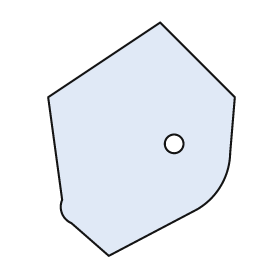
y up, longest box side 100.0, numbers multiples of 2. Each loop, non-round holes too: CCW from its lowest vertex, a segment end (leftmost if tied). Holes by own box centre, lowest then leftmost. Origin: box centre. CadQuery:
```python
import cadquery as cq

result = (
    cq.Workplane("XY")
    .moveTo(-14.0, -50.0)
    .lineTo(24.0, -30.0)
    .threePointArc((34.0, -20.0), (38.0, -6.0))
    .lineTo(40.0, 18.0)
    .lineTo(8.0, 50.0)
    .lineTo(-40.0, 18.0)
    .lineTo(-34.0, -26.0)
    .threePointArc((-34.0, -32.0), (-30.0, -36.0))
    .close()
    .moveTo(14.0, -2.0)
    .circle(4.0)
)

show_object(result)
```